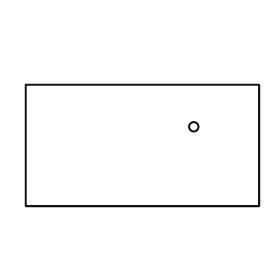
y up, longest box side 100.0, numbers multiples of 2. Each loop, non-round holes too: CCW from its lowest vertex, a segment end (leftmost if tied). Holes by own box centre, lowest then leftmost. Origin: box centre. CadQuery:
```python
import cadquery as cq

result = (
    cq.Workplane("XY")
    .moveTo(-50.0, -26.0)
    .lineTo(50.0, -26.0)
    .lineTo(50.0, 26.0)
    .lineTo(-50.0, 26.0)
    .close()
    .moveTo(22.0, 8.0)
    .circle(2.0)
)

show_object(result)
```